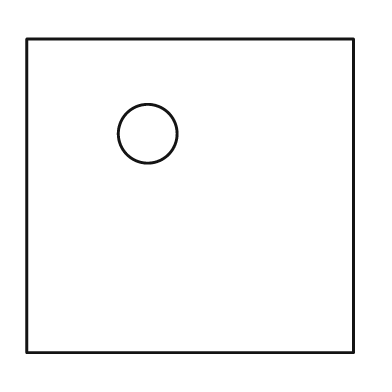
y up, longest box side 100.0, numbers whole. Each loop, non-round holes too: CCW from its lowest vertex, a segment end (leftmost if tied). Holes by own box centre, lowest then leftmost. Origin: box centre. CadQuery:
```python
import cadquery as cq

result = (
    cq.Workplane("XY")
    .moveTo(-50.0, -48.0)
    .lineTo(50.0, -48.0)
    .lineTo(50.0, 48.0)
    .lineTo(-50.0, 48.0)
    .close()
    .moveTo(-13.0, 19.0)
    .circle(9.0)
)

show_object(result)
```